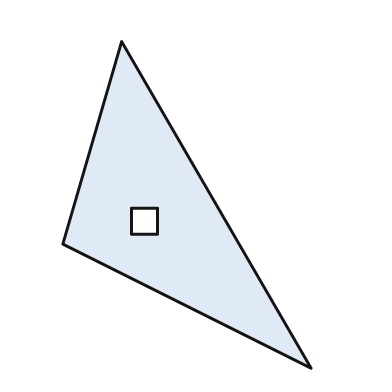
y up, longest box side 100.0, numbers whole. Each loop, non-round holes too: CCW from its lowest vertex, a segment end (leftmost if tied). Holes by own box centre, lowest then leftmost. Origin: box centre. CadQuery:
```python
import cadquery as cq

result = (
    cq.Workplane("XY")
    .moveTo(38.0, -50.0)
    .lineTo(-20.0, 50.0)
    .lineTo(-38.0, -12.0)
    .close()
    .moveTo(-17.0, -9.0)
    .lineTo(-9.0, -9.0)
    .lineTo(-9.0, -1.0)
    .lineTo(-17.0, -1.0)
    .close()
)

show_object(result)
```